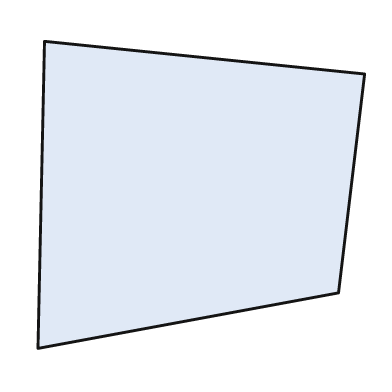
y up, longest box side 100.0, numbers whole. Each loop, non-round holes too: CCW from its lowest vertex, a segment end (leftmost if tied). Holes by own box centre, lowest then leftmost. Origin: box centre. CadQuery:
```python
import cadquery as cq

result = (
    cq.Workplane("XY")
    .moveTo(-50.0, -47.0)
    .lineTo(42.0, -30.0)
    .lineTo(50.0, 37.0)
    .lineTo(-48.0, 47.0)
    .close()
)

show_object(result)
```